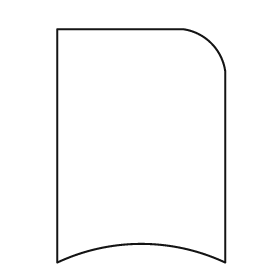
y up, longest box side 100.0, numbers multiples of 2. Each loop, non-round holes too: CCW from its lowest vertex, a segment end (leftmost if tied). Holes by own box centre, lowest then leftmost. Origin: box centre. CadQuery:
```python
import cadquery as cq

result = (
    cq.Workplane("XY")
    .moveTo(-36.0, -50.0)
    .threePointArc((0.0, -42.0), (36.0, -50.0))
    .lineTo(36.0, 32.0)
    .threePointArc((30.0, 44.0), (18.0, 50.0))
    .lineTo(-36.0, 50.0)
    .close()
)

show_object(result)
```